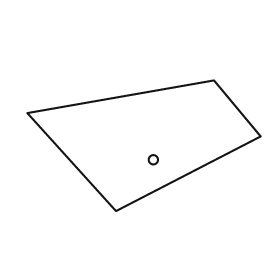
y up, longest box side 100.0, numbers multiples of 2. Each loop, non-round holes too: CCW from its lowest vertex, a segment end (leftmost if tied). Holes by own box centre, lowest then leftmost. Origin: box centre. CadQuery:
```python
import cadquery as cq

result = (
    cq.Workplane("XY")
    .moveTo(-12.0, -28.0)
    .lineTo(50.0, 4.0)
    .lineTo(30.0, 28.0)
    .lineTo(-50.0, 14.0)
    .close()
    .moveTo(4.0, -6.0)
    .circle(2.0)
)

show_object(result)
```